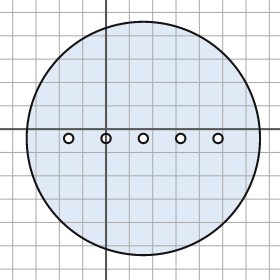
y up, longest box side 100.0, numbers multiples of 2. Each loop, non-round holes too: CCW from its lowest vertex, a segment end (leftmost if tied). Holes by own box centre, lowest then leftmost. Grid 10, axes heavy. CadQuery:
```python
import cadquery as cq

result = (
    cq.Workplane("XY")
    .moveTo(16.0, -4.0)
    .circle(50.0)
    .moveTo(-16.0, -4.0)
    .circle(2.0)
    .moveTo(0.0, -4.0)
    .circle(2.0)
    .moveTo(16.0, -4.0)
    .circle(2.0)
    .moveTo(32.0, -4.0)
    .circle(2.0)
    .moveTo(48.0, -4.0)
    .circle(2.0)
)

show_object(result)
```